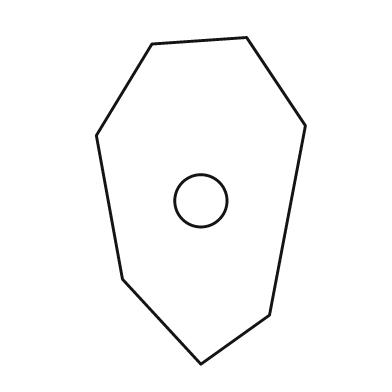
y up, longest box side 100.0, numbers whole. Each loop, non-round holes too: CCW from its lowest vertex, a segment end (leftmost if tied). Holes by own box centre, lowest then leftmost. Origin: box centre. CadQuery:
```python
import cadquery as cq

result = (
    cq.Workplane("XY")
    .moveTo(0.0, -50.0)
    .lineTo(21.0, -35.0)
    .lineTo(32.0, 23.0)
    .lineTo(14.0, 50.0)
    .lineTo(-15.0, 48.0)
    .lineTo(-32.0, 20.0)
    .lineTo(-24.0, -24.0)
    .close()
    .moveTo(0.0, 0.0)
    .circle(8.0)
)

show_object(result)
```